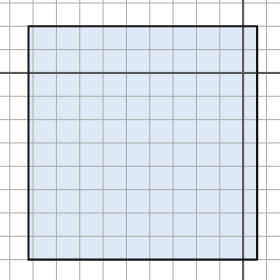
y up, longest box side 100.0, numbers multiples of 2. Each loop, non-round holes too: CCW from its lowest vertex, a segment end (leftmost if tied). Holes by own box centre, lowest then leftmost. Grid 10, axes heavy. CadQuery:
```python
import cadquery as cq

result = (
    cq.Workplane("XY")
    .moveTo(-92.0, -80.0)
    .lineTo(6.0, -80.0)
    .lineTo(6.0, 20.0)
    .lineTo(-92.0, 20.0)
    .close()
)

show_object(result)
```